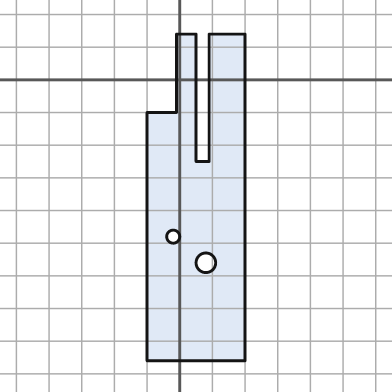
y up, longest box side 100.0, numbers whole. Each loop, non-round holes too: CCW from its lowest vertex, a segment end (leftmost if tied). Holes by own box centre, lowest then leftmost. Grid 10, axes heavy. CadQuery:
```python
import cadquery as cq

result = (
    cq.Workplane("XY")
    .moveTo(-10.0, -86.0)
    .lineTo(20.0, -86.0)
    .lineTo(20.0, 14.0)
    .lineTo(9.0, 14.0)
    .lineTo(9.0, -25.0)
    .lineTo(5.0, -25.0)
    .lineTo(5.0, 14.0)
    .lineTo(-1.0, 14.0)
    .lineTo(-1.0, -10.0)
    .lineTo(-10.0, -10.0)
    .close()
    .moveTo(8.0, -56.0)
    .circle(3.0)
    .moveTo(-2.0, -48.0)
    .circle(2.0)
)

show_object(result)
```